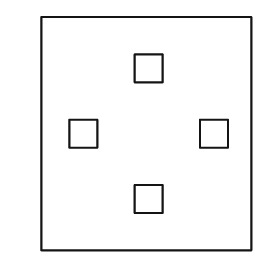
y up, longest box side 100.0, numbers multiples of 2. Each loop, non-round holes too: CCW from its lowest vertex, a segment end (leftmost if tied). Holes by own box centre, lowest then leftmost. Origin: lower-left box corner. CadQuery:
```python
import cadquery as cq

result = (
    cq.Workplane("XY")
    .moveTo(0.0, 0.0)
    .lineTo(90.0, 0.0)
    .lineTo(90.0, 100.0)
    .lineTo(0.0, 100.0)
    .close()
    .moveTo(40.0, 16.0)
    .lineTo(52.0, 16.0)
    .lineTo(52.0, 28.0)
    .lineTo(40.0, 28.0)
    .close()
    .moveTo(12.0, 44.0)
    .lineTo(24.0, 44.0)
    .lineTo(24.0, 56.0)
    .lineTo(12.0, 56.0)
    .close()
    .moveTo(68.0, 44.0)
    .lineTo(80.0, 44.0)
    .lineTo(80.0, 56.0)
    .lineTo(68.0, 56.0)
    .close()
    .moveTo(40.0, 72.0)
    .lineTo(52.0, 72.0)
    .lineTo(52.0, 84.0)
    .lineTo(40.0, 84.0)
    .close()
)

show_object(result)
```